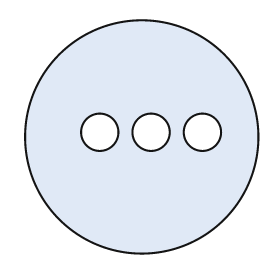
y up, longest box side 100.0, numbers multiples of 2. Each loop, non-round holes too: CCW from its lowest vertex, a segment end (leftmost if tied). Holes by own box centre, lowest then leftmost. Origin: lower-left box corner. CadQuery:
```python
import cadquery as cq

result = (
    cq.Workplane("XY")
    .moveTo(50.0, 50.0)
    .circle(50.0)
    .moveTo(32.0, 52.0)
    .circle(8.0)
    .moveTo(54.0, 52.0)
    .circle(8.0)
    .moveTo(76.0, 52.0)
    .circle(8.0)
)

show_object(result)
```